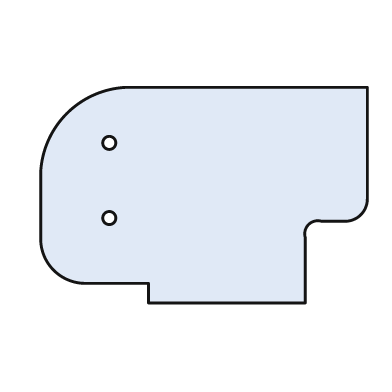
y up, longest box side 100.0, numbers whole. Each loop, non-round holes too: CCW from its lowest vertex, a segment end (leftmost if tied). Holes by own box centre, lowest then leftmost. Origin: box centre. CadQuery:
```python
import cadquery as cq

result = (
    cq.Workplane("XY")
    .moveTo(-17.0, -33.0)
    .lineTo(31.0, -33.0)
    .lineTo(31.0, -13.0)
    .threePointArc((32.0, -9.0), (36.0, -8.0))
    .lineTo(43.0, -8.0)
    .threePointArc((48.0, -6.0), (50.0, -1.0))
    .lineTo(50.0, 33.0)
    .lineTo(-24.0, 33.0)
    .threePointArc((-42.0, 25.0), (-50.0, 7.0))
    .lineTo(-50.0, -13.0)
    .threePointArc((-46.0, -23.0), (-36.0, -27.0))
    .lineTo(-17.0, -27.0)
    .close()
    .moveTo(-29.0, -7.0)
    .circle(2.0)
    .moveTo(-29.0, 16.0)
    .circle(2.0)
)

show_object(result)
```